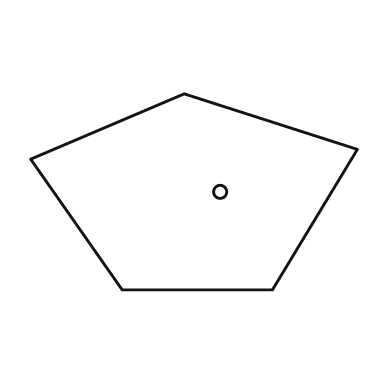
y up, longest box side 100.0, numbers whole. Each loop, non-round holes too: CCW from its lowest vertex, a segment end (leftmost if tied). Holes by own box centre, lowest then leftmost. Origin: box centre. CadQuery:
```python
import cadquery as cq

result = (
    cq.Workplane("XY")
    .moveTo(-22.0, -30.0)
    .lineTo(24.0, -30.0)
    .lineTo(50.0, 13.0)
    .lineTo(-3.0, 30.0)
    .lineTo(-50.0, 10.0)
    .close()
    .moveTo(8.0, 0.0)
    .circle(2.0)
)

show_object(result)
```